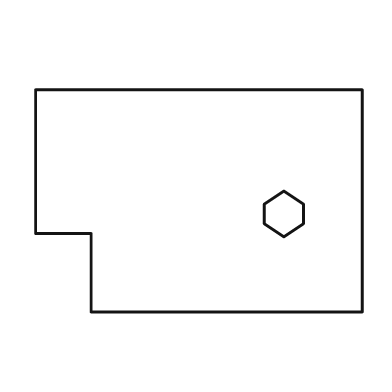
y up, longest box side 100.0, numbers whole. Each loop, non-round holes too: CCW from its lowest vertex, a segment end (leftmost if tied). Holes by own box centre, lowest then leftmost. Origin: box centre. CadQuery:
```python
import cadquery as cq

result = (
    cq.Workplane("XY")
    .moveTo(-33.0, -34.0)
    .lineTo(50.0, -34.0)
    .lineTo(50.0, 34.0)
    .lineTo(-50.0, 34.0)
    .lineTo(-50.0, -10.0)
    .lineTo(-33.0, -10.0)
    .close()
    .moveTo(26.0, -11.0)
    .lineTo(32.0, -7.0)
    .lineTo(32.0, -1.0)
    .lineTo(26.0, 3.0)
    .lineTo(20.0, -1.0)
    .lineTo(20.0, -7.0)
    .close()
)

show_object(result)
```